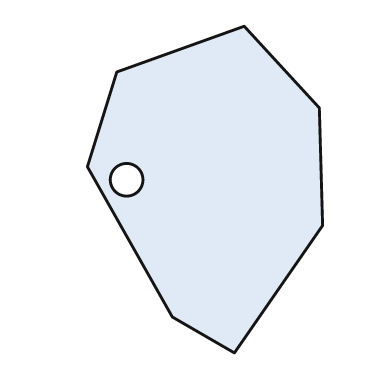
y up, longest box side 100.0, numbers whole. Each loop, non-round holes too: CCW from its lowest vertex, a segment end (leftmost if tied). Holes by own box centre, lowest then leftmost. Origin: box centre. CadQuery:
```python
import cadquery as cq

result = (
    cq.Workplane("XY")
    .moveTo(9.0, -50.0)
    .lineTo(36.0, -11.0)
    .lineTo(35.0, 25.0)
    .lineTo(12.0, 50.0)
    .lineTo(-27.0, 36.0)
    .lineTo(-36.0, 7.0)
    .lineTo(-10.0, -39.0)
    .close()
    .moveTo(-24.0, 3.0)
    .circle(5.0)
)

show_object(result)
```